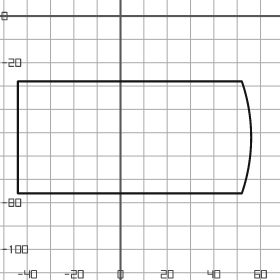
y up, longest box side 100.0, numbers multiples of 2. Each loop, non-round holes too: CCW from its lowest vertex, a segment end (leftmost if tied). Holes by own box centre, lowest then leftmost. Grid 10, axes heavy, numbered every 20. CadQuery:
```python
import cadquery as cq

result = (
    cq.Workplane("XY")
    .moveTo(-44.0, -76.0)
    .lineTo(52.0, -76.0)
    .threePointArc((56.0, -52.0), (52.0, -28.0))
    .lineTo(-44.0, -28.0)
    .close()
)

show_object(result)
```